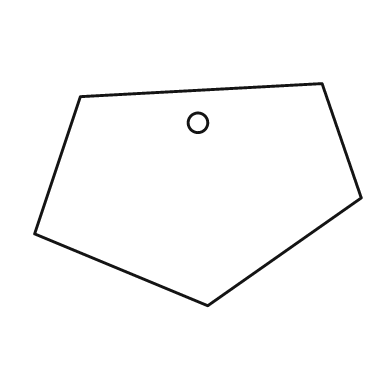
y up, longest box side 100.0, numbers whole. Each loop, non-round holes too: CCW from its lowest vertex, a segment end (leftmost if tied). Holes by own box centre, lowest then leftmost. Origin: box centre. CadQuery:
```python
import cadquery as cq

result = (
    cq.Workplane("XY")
    .moveTo(3.0, -34.0)
    .lineTo(50.0, -1.0)
    .lineTo(38.0, 34.0)
    .lineTo(-36.0, 30.0)
    .lineTo(-50.0, -12.0)
    .close()
    .moveTo(0.0, 22.0)
    .circle(3.0)
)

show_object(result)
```